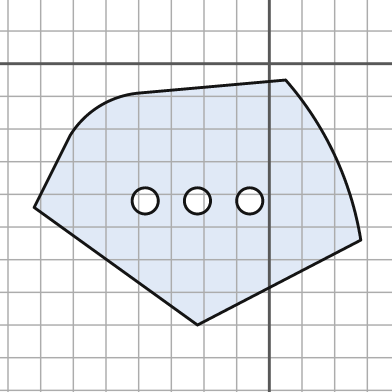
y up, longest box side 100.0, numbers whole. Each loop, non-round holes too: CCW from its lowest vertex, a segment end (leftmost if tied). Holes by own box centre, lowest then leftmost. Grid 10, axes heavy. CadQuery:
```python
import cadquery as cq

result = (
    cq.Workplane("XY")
    .moveTo(-22.0, -80.0)
    .lineTo(28.0, -54.0)
    .threePointArc((20.0, -28.0), (5.0, -5.0))
    .lineTo(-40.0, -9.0)
    .threePointArc((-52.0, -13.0), (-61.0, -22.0))
    .lineTo(-72.0, -44.0)
    .close()
    .moveTo(-38.0, -42.0)
    .circle(4.0)
    .moveTo(-22.0, -42.0)
    .circle(4.0)
    .moveTo(-6.0, -42.0)
    .circle(4.0)
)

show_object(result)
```